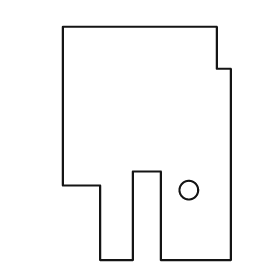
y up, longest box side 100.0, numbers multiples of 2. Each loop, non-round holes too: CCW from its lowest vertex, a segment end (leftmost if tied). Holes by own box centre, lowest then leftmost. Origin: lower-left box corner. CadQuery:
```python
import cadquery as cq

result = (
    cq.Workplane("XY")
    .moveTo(16.0, 0.0)
    .lineTo(30.0, 0.0)
    .lineTo(30.0, 38.0)
    .lineTo(42.0, 38.0)
    .lineTo(42.0, 0.0)
    .lineTo(72.0, 0.0)
    .lineTo(72.0, 82.0)
    .lineTo(66.0, 82.0)
    .lineTo(66.0, 100.0)
    .lineTo(0.0, 100.0)
    .lineTo(0.0, 32.0)
    .lineTo(16.0, 32.0)
    .close()
    .moveTo(54.0, 30.0)
    .circle(4.0)
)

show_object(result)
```